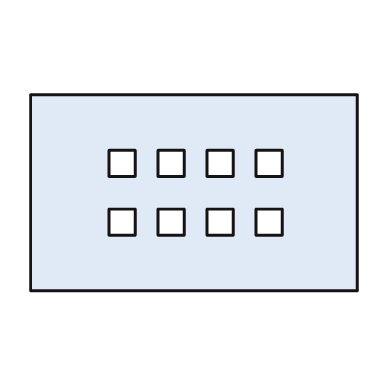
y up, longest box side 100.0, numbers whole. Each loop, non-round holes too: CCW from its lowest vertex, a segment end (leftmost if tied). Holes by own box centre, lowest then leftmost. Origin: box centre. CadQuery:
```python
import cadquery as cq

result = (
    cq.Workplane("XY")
    .moveTo(-50.0, -30.0)
    .lineTo(50.0, -30.0)
    .lineTo(50.0, 30.0)
    .lineTo(-50.0, 30.0)
    .close()
    .moveTo(-26.0, -13.0)
    .lineTo(-18.0, -13.0)
    .lineTo(-18.0, -5.0)
    .lineTo(-26.0, -5.0)
    .close()
    .moveTo(-11.0, -13.0)
    .lineTo(-3.0, -13.0)
    .lineTo(-3.0, -5.0)
    .lineTo(-11.0, -5.0)
    .close()
    .moveTo(4.0, -13.0)
    .lineTo(12.0, -13.0)
    .lineTo(12.0, -5.0)
    .lineTo(4.0, -5.0)
    .close()
    .moveTo(19.0, -13.0)
    .lineTo(27.0, -13.0)
    .lineTo(27.0, -5.0)
    .lineTo(19.0, -5.0)
    .close()
    .moveTo(-26.0, 5.0)
    .lineTo(-18.0, 5.0)
    .lineTo(-18.0, 13.0)
    .lineTo(-26.0, 13.0)
    .close()
    .moveTo(-11.0, 5.0)
    .lineTo(-3.0, 5.0)
    .lineTo(-3.0, 13.0)
    .lineTo(-11.0, 13.0)
    .close()
    .moveTo(4.0, 5.0)
    .lineTo(12.0, 5.0)
    .lineTo(12.0, 13.0)
    .lineTo(4.0, 13.0)
    .close()
    .moveTo(19.0, 5.0)
    .lineTo(27.0, 5.0)
    .lineTo(27.0, 13.0)
    .lineTo(19.0, 13.0)
    .close()
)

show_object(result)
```